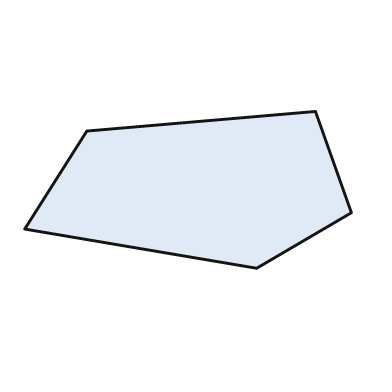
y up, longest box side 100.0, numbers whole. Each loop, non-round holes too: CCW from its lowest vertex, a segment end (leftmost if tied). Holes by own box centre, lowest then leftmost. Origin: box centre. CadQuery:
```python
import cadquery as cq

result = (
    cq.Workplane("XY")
    .moveTo(21.0, -24.0)
    .lineTo(50.0, -7.0)
    .lineTo(39.0, 24.0)
    .lineTo(-31.0, 18.0)
    .lineTo(-50.0, -12.0)
    .close()
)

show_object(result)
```